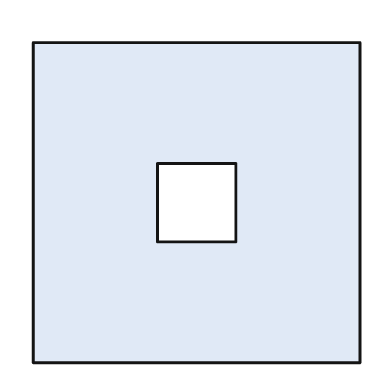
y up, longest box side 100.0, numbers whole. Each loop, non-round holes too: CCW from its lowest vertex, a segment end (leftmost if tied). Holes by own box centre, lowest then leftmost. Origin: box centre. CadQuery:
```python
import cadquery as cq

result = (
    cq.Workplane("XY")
    .moveTo(-50.0, -49.0)
    .lineTo(50.0, -49.0)
    .lineTo(50.0, 49.0)
    .lineTo(-50.0, 49.0)
    .close()
    .moveTo(-12.0, -12.0)
    .lineTo(12.0, -12.0)
    .lineTo(12.0, 12.0)
    .lineTo(-12.0, 12.0)
    .close()
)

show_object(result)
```